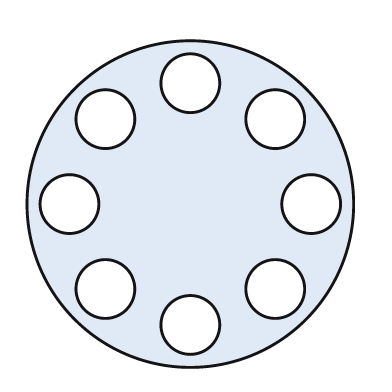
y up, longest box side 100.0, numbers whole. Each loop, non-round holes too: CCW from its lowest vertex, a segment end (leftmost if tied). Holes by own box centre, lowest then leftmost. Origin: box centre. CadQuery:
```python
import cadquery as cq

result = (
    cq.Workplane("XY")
    .moveTo(0.0, 0.0)
    .circle(50.0)
    .moveTo(0.0, -37.0)
    .circle(9.0)
    .moveTo(-26.0, -26.0)
    .circle(9.0)
    .moveTo(26.0, -26.0)
    .circle(9.0)
    .moveTo(-37.0, 0.0)
    .circle(9.0)
    .moveTo(37.0, 0.0)
    .circle(9.0)
    .moveTo(-26.0, 26.0)
    .circle(9.0)
    .moveTo(26.0, 26.0)
    .circle(9.0)
    .moveTo(0.0, 37.0)
    .circle(9.0)
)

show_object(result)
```